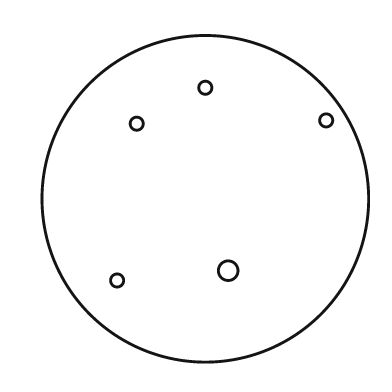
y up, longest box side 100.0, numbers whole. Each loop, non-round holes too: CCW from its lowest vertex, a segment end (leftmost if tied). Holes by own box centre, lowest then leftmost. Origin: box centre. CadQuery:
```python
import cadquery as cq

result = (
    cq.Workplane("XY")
    .moveTo(0.0, 0.0)
    .circle(50.0)
    .moveTo(-27.0, -25.0)
    .circle(2.0)
    .moveTo(7.0, -22.0)
    .circle(3.0)
    .moveTo(-21.0, 23.0)
    .circle(2.0)
    .moveTo(37.0, 24.0)
    .circle(2.0)
    .moveTo(0.0, 34.0)
    .circle(2.0)
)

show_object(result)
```